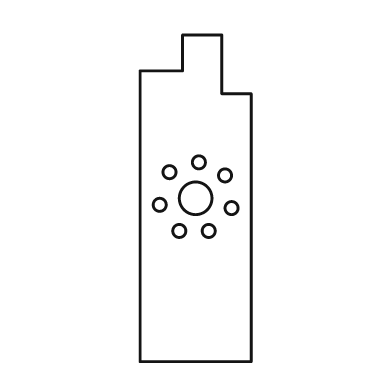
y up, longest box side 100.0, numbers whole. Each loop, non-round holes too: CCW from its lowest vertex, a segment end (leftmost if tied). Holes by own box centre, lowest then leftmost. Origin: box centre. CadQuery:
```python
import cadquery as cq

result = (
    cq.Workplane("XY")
    .moveTo(-17.0, -50.0)
    .lineTo(17.0, -50.0)
    .lineTo(17.0, 32.0)
    .lineTo(8.0, 32.0)
    .lineTo(8.0, 50.0)
    .lineTo(-4.0, 50.0)
    .lineTo(-4.0, 39.0)
    .lineTo(-17.0, 39.0)
    .close()
    .moveTo(-5.0, -10.0)
    .circle(2.0)
    .moveTo(4.0, -10.0)
    .circle(2.0)
    .moveTo(11.0, -3.0)
    .circle(2.0)
    .moveTo(-11.0, -2.0)
    .circle(2.0)
    .moveTo(0.0, 0.0)
    .circle(5.0)
    .moveTo(9.0, 7.0)
    .circle(2.0)
    .moveTo(-8.0, 8.0)
    .circle(2.0)
    .moveTo(1.0, 11.0)
    .circle(2.0)
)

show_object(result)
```